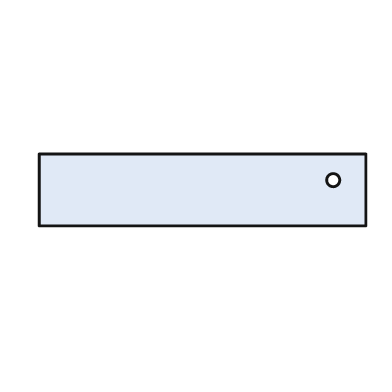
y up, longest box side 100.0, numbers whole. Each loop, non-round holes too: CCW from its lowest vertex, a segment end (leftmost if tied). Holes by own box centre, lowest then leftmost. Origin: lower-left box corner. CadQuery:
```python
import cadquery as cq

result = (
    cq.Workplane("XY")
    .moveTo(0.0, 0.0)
    .lineTo(100.0, 0.0)
    .lineTo(100.0, 22.0)
    .lineTo(0.0, 22.0)
    .close()
    .moveTo(90.0, 14.0)
    .circle(2.0)
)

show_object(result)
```